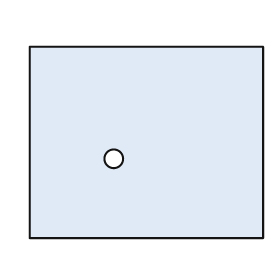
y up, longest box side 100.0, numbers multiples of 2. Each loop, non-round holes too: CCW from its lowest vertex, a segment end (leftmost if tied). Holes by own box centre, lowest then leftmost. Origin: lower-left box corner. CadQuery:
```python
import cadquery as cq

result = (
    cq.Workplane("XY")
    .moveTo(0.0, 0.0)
    .lineTo(100.0, 0.0)
    .lineTo(100.0, 82.0)
    .lineTo(0.0, 82.0)
    .close()
    .moveTo(36.0, 34.0)
    .circle(4.0)
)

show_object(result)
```